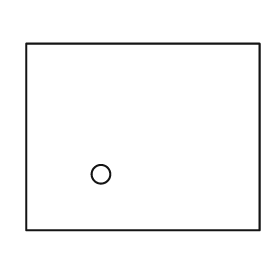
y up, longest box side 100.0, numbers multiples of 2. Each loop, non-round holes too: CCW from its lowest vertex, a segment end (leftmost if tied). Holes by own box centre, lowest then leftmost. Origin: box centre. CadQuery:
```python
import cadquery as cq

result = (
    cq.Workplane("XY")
    .moveTo(-50.0, -40.0)
    .lineTo(50.0, -40.0)
    .lineTo(50.0, 40.0)
    .lineTo(-50.0, 40.0)
    .close()
    .moveTo(-18.0, -16.0)
    .circle(4.0)
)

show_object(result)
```